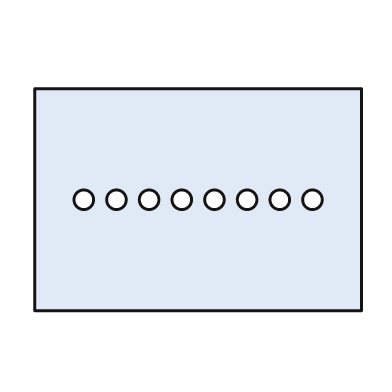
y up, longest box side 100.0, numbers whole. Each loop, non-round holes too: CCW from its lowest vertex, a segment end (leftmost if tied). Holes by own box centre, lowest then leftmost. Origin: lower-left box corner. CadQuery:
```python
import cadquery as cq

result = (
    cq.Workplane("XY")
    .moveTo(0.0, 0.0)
    .lineTo(100.0, 0.0)
    .lineTo(100.0, 68.0)
    .lineTo(0.0, 68.0)
    .close()
    .moveTo(15.0, 34.0)
    .circle(3.0)
    .moveTo(25.0, 34.0)
    .circle(3.0)
    .moveTo(35.0, 34.0)
    .circle(3.0)
    .moveTo(45.0, 34.0)
    .circle(3.0)
    .moveTo(55.0, 34.0)
    .circle(3.0)
    .moveTo(65.0, 34.0)
    .circle(3.0)
    .moveTo(75.0, 34.0)
    .circle(3.0)
    .moveTo(85.0, 34.0)
    .circle(3.0)
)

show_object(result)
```